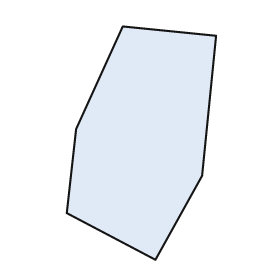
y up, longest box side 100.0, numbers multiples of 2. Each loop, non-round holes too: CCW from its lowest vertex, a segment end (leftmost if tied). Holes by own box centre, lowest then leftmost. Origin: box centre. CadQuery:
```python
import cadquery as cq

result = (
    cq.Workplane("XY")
    .moveTo(6.0, -50.0)
    .lineTo(26.0, -14.0)
    .lineTo(32.0, 46.0)
    .lineTo(-8.0, 50.0)
    .lineTo(-28.0, 6.0)
    .lineTo(-32.0, -30.0)
    .close()
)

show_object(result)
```